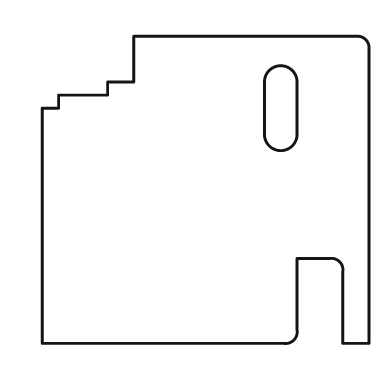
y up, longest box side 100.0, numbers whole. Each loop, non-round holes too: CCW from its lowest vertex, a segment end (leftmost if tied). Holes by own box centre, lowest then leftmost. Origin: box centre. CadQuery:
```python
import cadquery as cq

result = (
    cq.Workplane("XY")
    .moveTo(-50.0, -47.0)
    .lineTo(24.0, -47.0)
    .threePointArc((27.0, -46.0), (28.0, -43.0))
    .lineTo(28.0, -21.0)
    .lineTo(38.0, -21.0)
    .threePointArc((41.0, -22.0), (42.0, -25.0))
    .lineTo(42.0, -47.0)
    .lineTo(50.0, -47.0)
    .lineTo(50.0, 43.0)
    .threePointArc((49.0, 46.0), (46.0, 47.0))
    .lineTo(-22.0, 47.0)
    .lineTo(-22.0, 33.0)
    .lineTo(-30.0, 33.0)
    .lineTo(-30.0, 29.0)
    .lineTo(-45.0, 29.0)
    .lineTo(-45.0, 25.0)
    .lineTo(-50.0, 25.0)
    .close()
    .moveTo(18.0, 17.0)
    .threePointArc((23.0, 12.0), (28.0, 17.0))
    .lineTo(28.0, 33.0)
    .threePointArc((23.0, 38.0), (18.0, 33.0))
    .close()
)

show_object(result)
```